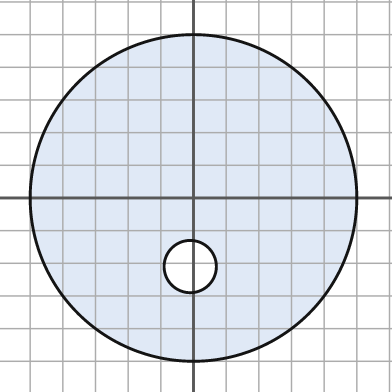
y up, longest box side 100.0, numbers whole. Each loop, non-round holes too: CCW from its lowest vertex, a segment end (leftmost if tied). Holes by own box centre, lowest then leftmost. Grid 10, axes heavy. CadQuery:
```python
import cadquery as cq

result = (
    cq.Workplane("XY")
    .moveTo(0.0, 0.0)
    .circle(50.0)
    .moveTo(-1.0, -21.0)
    .circle(8.0)
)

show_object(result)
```